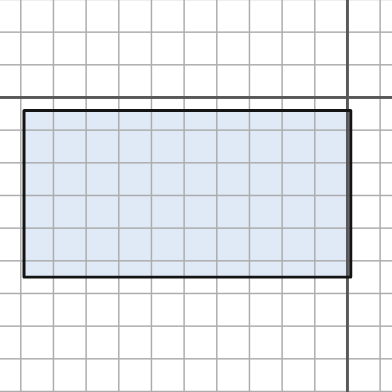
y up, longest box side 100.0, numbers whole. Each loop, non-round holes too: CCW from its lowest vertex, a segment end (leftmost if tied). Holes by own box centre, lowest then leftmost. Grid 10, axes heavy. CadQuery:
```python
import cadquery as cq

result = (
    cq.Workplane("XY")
    .moveTo(-99.0, -55.0)
    .lineTo(1.0, -55.0)
    .lineTo(1.0, -4.0)
    .lineTo(-99.0, -4.0)
    .close()
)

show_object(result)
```